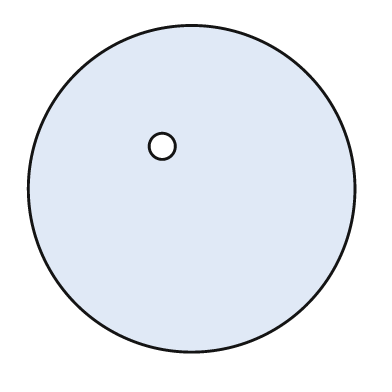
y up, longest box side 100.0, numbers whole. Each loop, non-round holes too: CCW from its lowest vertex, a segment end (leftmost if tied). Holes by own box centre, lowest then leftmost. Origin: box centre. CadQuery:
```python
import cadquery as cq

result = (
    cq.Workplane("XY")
    .moveTo(0.0, 0.0)
    .circle(50.0)
    .moveTo(-9.0, 13.0)
    .circle(4.0)
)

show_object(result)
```